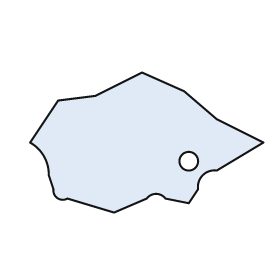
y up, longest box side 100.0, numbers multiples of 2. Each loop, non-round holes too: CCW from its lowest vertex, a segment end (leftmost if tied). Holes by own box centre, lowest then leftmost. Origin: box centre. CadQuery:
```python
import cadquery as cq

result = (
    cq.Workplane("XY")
    .moveTo(-14.0, -30.0)
    .lineTo(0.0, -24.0)
    .threePointArc((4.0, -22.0), (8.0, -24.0))
    .lineTo(18.0, -26.0)
    .lineTo(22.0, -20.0)
    .threePointArc((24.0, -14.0), (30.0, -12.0))
    .lineTo(50.0, 0.0)
    .lineTo(30.0, 10.0)
    .lineTo(16.0, 22.0)
    .lineTo(-2.0, 30.0)
    .lineTo(-22.0, 20.0)
    .lineTo(-38.0, 18.0)
    .lineTo(-50.0, 0.0)
    .threePointArc((-44.0, -6.0), (-42.0, -14.0))
    .lineTo(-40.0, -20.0)
    .threePointArc((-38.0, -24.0), (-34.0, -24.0))
    .close()
    .moveTo(18.0, -8.0)
    .circle(4.0)
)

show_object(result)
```